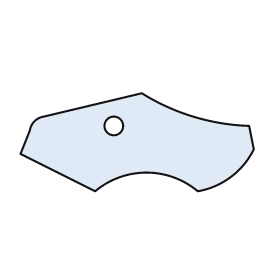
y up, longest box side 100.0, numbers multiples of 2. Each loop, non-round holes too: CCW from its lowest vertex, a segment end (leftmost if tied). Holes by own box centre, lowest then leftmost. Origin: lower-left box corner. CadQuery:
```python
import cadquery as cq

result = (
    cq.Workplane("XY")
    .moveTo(32.0, 0.0)
    .threePointArc((54.0, 8.0), (76.0, 0.0))
    .threePointArc((90.0, 6.0), (100.0, 18.0))
    .lineTo(98.0, 28.0)
    .threePointArc((74.0, 32.0), (52.0, 42.0))
    .lineTo(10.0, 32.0)
    .threePointArc((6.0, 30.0), (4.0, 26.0))
    .lineTo(0.0, 16.0)
    .close()
    .moveTo(40.0, 28.0)
    .circle(4.0)
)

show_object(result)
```